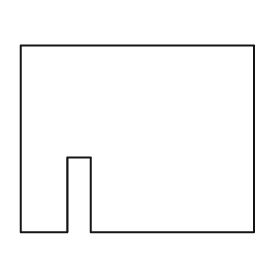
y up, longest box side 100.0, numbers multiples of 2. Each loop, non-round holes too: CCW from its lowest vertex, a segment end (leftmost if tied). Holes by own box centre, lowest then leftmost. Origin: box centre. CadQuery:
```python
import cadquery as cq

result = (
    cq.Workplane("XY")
    .moveTo(-50.0, -40.0)
    .lineTo(-30.0, -40.0)
    .lineTo(-30.0, -8.0)
    .lineTo(-20.0, -8.0)
    .lineTo(-20.0, -40.0)
    .lineTo(50.0, -40.0)
    .lineTo(50.0, 40.0)
    .lineTo(-50.0, 40.0)
    .close()
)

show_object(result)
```